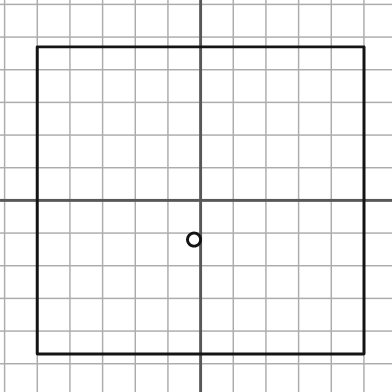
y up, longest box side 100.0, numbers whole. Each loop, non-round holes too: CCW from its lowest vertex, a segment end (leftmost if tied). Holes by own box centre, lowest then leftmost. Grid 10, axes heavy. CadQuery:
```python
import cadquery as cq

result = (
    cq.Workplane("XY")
    .moveTo(-50.0, -47.0)
    .lineTo(50.0, -47.0)
    .lineTo(50.0, 47.0)
    .lineTo(-50.0, 47.0)
    .close()
    .moveTo(-2.0, -12.0)
    .circle(2.0)
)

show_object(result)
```